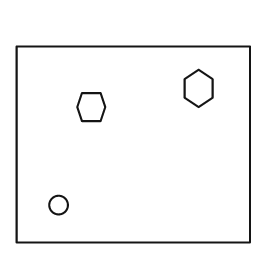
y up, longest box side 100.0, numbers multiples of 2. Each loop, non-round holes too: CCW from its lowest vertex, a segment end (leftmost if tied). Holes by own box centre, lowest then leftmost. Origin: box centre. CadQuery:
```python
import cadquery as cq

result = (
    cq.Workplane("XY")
    .moveTo(-50.0, -42.0)
    .lineTo(50.0, -42.0)
    .lineTo(50.0, 42.0)
    .lineTo(-50.0, 42.0)
    .close()
    .moveTo(-32.0, -26.0)
    .circle(4.0)
    .moveTo(-22.0, 10.0)
    .lineTo(-14.0, 10.0)
    .lineTo(-12.0, 16.0)
    .lineTo(-14.0, 22.0)
    .lineTo(-22.0, 22.0)
    .lineTo(-24.0, 16.0)
    .close()
    .moveTo(28.0, 16.0)
    .lineTo(34.0, 20.0)
    .lineTo(34.0, 28.0)
    .lineTo(28.0, 32.0)
    .lineTo(22.0, 28.0)
    .lineTo(22.0, 20.0)
    .close()
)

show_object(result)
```